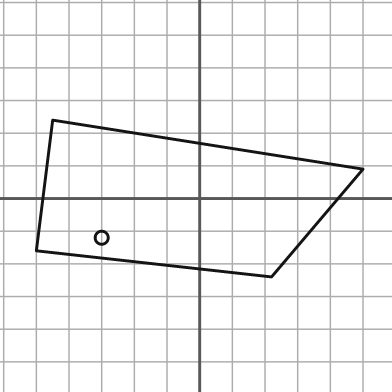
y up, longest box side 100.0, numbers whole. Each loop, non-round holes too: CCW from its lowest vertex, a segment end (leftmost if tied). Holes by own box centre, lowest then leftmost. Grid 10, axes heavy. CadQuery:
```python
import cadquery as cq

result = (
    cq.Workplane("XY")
    .moveTo(22.0, -24.0)
    .lineTo(50.0, 9.0)
    .lineTo(-45.0, 24.0)
    .lineTo(-50.0, -16.0)
    .close()
    .moveTo(-30.0, -12.0)
    .circle(2.0)
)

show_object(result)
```